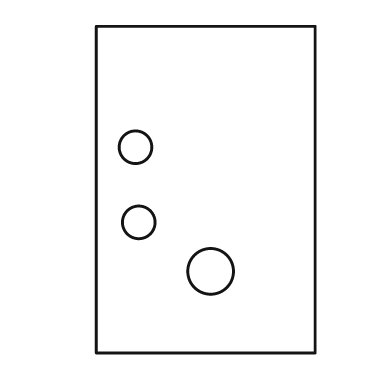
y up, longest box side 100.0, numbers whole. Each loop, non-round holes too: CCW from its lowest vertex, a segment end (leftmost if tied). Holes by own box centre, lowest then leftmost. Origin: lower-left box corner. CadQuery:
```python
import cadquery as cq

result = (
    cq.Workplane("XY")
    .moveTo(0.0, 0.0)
    .lineTo(67.0, 0.0)
    .lineTo(67.0, 100.0)
    .lineTo(0.0, 100.0)
    .close()
    .moveTo(35.0, 25.0)
    .circle(7.0)
    .moveTo(13.0, 40.0)
    .circle(5.0)
    .moveTo(12.0, 63.0)
    .circle(5.0)
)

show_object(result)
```